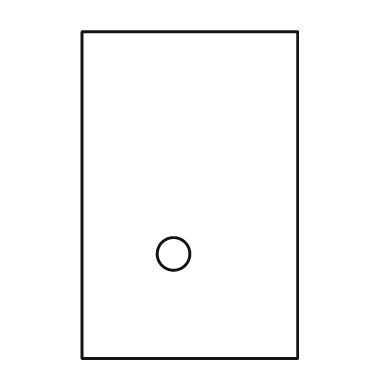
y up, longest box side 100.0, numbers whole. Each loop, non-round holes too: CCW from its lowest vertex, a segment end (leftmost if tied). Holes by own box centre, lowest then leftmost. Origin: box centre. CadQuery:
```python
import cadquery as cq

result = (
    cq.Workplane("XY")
    .moveTo(-33.0, -50.0)
    .lineTo(33.0, -50.0)
    .lineTo(33.0, 50.0)
    .lineTo(-33.0, 50.0)
    .close()
    .moveTo(-5.0, -18.0)
    .circle(5.0)
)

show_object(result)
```